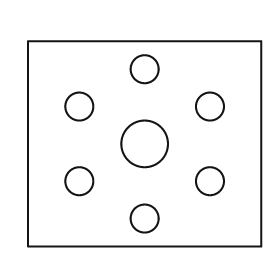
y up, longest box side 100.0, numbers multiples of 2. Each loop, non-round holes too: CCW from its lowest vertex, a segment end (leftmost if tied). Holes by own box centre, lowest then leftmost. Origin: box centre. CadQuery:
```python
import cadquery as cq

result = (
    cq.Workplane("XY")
    .moveTo(-50.0, -44.0)
    .lineTo(50.0, -44.0)
    .lineTo(50.0, 44.0)
    .lineTo(-50.0, 44.0)
    .close()
    .moveTo(0.0, -32.0)
    .circle(6.0)
    .moveTo(-28.0, -16.0)
    .circle(6.0)
    .moveTo(28.0, -16.0)
    .circle(6.0)
    .moveTo(0.0, 0.0)
    .circle(10.0)
    .moveTo(-28.0, 16.0)
    .circle(6.0)
    .moveTo(28.0, 16.0)
    .circle(6.0)
    .moveTo(0.0, 32.0)
    .circle(6.0)
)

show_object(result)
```